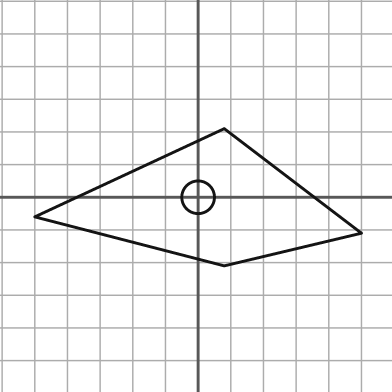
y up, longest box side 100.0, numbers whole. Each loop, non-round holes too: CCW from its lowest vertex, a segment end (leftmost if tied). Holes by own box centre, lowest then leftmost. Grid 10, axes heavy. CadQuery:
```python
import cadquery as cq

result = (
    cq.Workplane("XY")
    .moveTo(8.0, -21.0)
    .lineTo(50.0, -11.0)
    .lineTo(8.0, 21.0)
    .lineTo(-50.0, -6.0)
    .close()
    .moveTo(0.0, 0.0)
    .circle(5.0)
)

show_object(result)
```